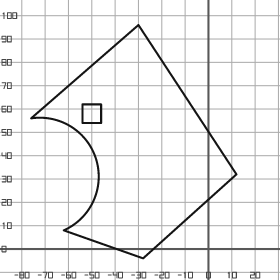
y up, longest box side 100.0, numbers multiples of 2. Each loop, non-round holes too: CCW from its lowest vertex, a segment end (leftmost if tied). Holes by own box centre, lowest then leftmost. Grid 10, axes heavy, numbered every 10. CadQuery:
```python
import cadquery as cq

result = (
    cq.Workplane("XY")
    .moveTo(-28.0, -4.0)
    .lineTo(12.0, 32.0)
    .lineTo(-30.0, 96.0)
    .lineTo(-76.0, 56.0)
    .threePointArc((-48.0, 38.0), (-62.0, 8.0))
    .close()
    .moveTo(-54.0, 54.0)
    .lineTo(-46.0, 54.0)
    .lineTo(-46.0, 62.0)
    .lineTo(-54.0, 62.0)
    .close()
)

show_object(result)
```